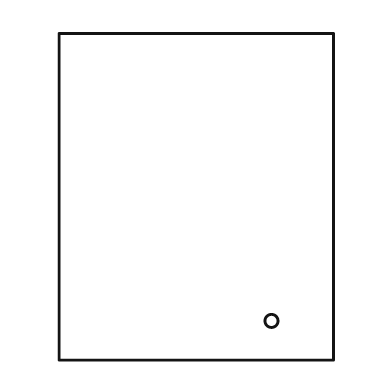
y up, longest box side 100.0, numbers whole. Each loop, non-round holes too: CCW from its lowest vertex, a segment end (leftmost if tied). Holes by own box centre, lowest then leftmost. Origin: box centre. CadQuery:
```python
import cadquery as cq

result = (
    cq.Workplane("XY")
    .moveTo(-42.0, -50.0)
    .lineTo(42.0, -50.0)
    .lineTo(42.0, 50.0)
    .lineTo(-42.0, 50.0)
    .close()
    .moveTo(23.0, -38.0)
    .circle(2.0)
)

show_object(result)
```